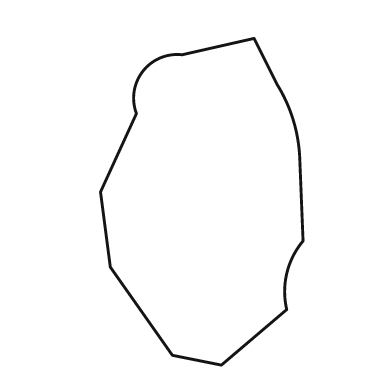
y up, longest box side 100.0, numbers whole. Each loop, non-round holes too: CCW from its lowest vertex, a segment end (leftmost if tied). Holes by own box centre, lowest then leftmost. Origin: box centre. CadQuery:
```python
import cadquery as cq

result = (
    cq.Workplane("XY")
    .moveTo(6.0, -50.0)
    .lineTo(26.0, -33.0)
    .threePointArc((26.0, -22.0), (31.0, -12.0))
    .lineTo(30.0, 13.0)
    .threePointArc((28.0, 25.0), (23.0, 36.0))
    .lineTo(16.0, 50.0)
    .lineTo(-6.0, 45.0)
    .threePointArc((-18.0, 40.0), (-20.0, 27.0))
    .lineTo(-31.0, 3.0)
    .lineTo(-28.0, -20.0)
    .lineTo(-9.0, -47.0)
    .close()
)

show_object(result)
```